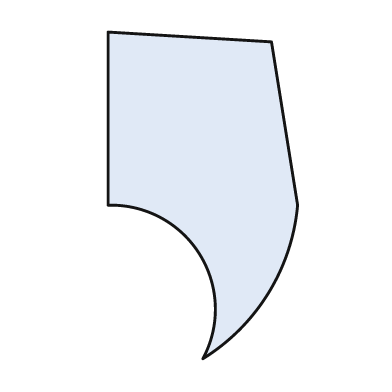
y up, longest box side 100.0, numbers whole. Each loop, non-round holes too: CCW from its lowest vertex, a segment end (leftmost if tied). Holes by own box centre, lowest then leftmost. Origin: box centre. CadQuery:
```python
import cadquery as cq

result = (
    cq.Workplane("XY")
    .moveTo(0.0, -50.0)
    .threePointArc((20.0, -30.0), (29.0, -3.0))
    .lineTo(21.0, 47.0)
    .lineTo(-29.0, 50.0)
    .lineTo(-29.0, -3.0)
    .threePointArc((-1.0, -18.0), (0.0, -50.0))
    .close()
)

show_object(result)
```